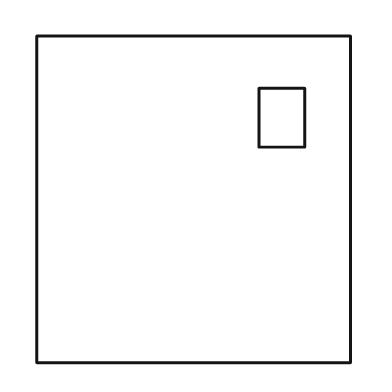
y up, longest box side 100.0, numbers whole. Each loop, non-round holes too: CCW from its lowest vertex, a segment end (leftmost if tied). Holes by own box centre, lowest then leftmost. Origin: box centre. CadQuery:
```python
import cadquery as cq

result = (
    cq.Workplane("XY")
    .moveTo(-48.0, -50.0)
    .lineTo(48.0, -50.0)
    .lineTo(48.0, 50.0)
    .lineTo(-48.0, 50.0)
    .close()
    .moveTo(20.0, 16.0)
    .lineTo(34.0, 16.0)
    .lineTo(34.0, 34.0)
    .lineTo(20.0, 34.0)
    .close()
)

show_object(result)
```